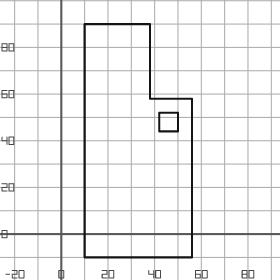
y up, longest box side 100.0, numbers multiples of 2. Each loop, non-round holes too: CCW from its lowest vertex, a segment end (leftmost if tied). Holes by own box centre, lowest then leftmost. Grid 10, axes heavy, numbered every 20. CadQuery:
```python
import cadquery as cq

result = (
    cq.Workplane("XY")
    .moveTo(10.0, -10.0)
    .lineTo(56.0, -10.0)
    .lineTo(56.0, 58.0)
    .lineTo(38.0, 58.0)
    .lineTo(38.0, 90.0)
    .lineTo(10.0, 90.0)
    .close()
    .moveTo(42.0, 44.0)
    .lineTo(50.0, 44.0)
    .lineTo(50.0, 52.0)
    .lineTo(42.0, 52.0)
    .close()
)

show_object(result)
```